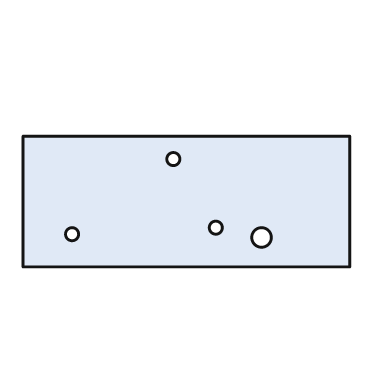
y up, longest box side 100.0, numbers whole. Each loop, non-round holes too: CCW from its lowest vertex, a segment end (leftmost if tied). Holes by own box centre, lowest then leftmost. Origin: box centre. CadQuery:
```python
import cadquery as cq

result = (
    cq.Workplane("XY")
    .moveTo(-50.0, -20.0)
    .lineTo(50.0, -20.0)
    .lineTo(50.0, 20.0)
    .lineTo(-50.0, 20.0)
    .close()
    .moveTo(23.0, -11.0)
    .circle(3.0)
    .moveTo(-35.0, -10.0)
    .circle(2.0)
    .moveTo(9.0, -8.0)
    .circle(2.0)
    .moveTo(-4.0, 13.0)
    .circle(2.0)
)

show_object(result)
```